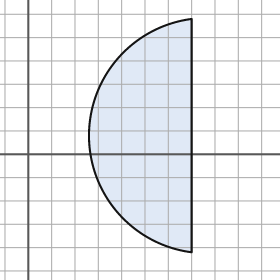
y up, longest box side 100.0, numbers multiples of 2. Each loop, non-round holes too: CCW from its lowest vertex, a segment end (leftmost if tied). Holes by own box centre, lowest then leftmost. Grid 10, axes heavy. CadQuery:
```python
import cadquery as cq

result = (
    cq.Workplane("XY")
    .moveTo(70.0, -42.0)
    .lineTo(70.0, 58.0)
    .threePointArc((26.0, 8.0), (70.0, -42.0))
    .close()
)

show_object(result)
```